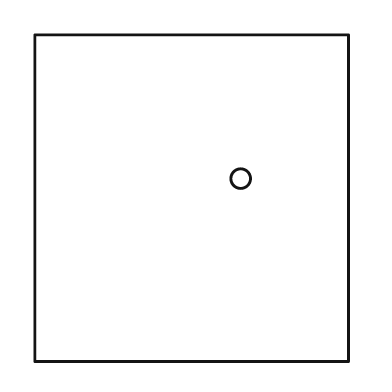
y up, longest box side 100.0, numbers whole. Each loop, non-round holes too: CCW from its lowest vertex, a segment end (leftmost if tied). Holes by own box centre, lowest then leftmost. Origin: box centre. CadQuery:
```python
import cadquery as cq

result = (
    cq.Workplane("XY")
    .moveTo(-48.0, -50.0)
    .lineTo(48.0, -50.0)
    .lineTo(48.0, 50.0)
    .lineTo(-48.0, 50.0)
    .close()
    .moveTo(15.0, 6.0)
    .circle(3.0)
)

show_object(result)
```